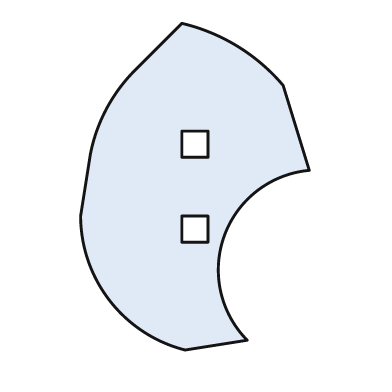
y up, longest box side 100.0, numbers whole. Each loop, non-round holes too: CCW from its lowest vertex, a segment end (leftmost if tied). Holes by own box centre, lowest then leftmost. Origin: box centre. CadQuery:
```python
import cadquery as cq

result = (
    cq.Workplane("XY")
    .moveTo(-3.0, -50.0)
    .lineTo(16.0, -47.0)
    .threePointArc((9.0, -15.0), (35.0, 5.0))
    .lineTo(27.0, 31.0)
    .threePointArc((13.0, 43.0), (-4.0, 50.0))
    .lineTo(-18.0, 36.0)
    .threePointArc((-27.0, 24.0), (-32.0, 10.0))
    .lineTo(-35.0, -9.0)
    .threePointArc((-26.0, -35.0), (-3.0, -50.0))
    .close()
    .moveTo(-4.0, -17.0)
    .lineTo(4.0, -17.0)
    .lineTo(4.0, -9.0)
    .lineTo(-4.0, -9.0)
    .close()
    .moveTo(-4.0, 9.0)
    .lineTo(4.0, 9.0)
    .lineTo(4.0, 17.0)
    .lineTo(-4.0, 17.0)
    .close()
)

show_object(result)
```